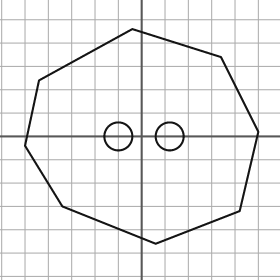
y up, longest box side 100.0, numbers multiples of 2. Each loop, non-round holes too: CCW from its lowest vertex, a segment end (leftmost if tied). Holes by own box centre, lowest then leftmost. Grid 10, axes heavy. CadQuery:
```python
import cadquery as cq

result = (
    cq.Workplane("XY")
    .moveTo(6.0, -46.0)
    .lineTo(42.0, -32.0)
    .lineTo(50.0, 2.0)
    .lineTo(34.0, 34.0)
    .lineTo(-4.0, 46.0)
    .lineTo(-44.0, 24.0)
    .lineTo(-50.0, -4.0)
    .lineTo(-34.0, -30.0)
    .close()
    .moveTo(-10.0, 0.0)
    .circle(6.0)
    .moveTo(12.0, 0.0)
    .circle(6.0)
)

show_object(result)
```